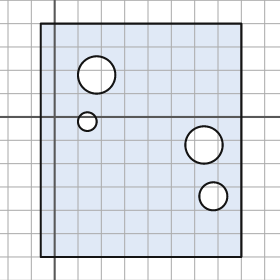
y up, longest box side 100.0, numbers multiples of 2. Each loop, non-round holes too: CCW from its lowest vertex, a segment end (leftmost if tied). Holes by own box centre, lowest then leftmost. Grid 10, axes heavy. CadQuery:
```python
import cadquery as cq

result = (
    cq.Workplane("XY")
    .moveTo(-6.0, -60.0)
    .lineTo(80.0, -60.0)
    .lineTo(80.0, 40.0)
    .lineTo(-6.0, 40.0)
    .close()
    .moveTo(68.0, -34.0)
    .circle(6.0)
    .moveTo(64.0, -12.0)
    .circle(8.0)
    .moveTo(14.0, -2.0)
    .circle(4.0)
    .moveTo(18.0, 18.0)
    .circle(8.0)
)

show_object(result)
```